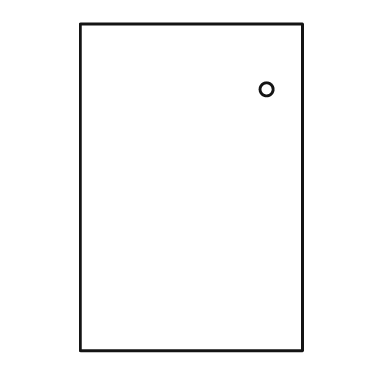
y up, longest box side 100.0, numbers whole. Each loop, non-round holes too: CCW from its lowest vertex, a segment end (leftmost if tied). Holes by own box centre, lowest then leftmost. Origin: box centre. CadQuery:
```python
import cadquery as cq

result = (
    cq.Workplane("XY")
    .moveTo(-34.0, -50.0)
    .lineTo(34.0, -50.0)
    .lineTo(34.0, 50.0)
    .lineTo(-34.0, 50.0)
    .close()
    .moveTo(23.0, 30.0)
    .circle(2.0)
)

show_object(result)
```